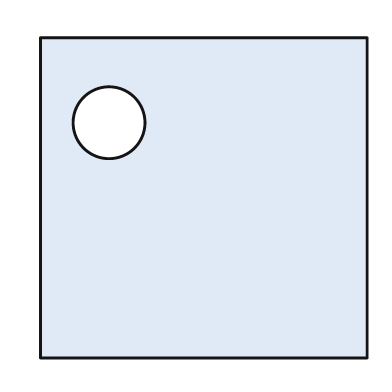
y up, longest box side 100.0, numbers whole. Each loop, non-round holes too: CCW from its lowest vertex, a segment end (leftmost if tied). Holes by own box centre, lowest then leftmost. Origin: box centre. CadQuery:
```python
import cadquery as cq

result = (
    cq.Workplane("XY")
    .moveTo(-50.0, -49.0)
    .lineTo(50.0, -49.0)
    .lineTo(50.0, 49.0)
    .lineTo(-50.0, 49.0)
    .close()
    .moveTo(-29.0, 23.0)
    .circle(11.0)
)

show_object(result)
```